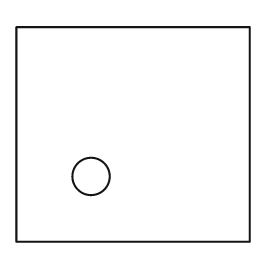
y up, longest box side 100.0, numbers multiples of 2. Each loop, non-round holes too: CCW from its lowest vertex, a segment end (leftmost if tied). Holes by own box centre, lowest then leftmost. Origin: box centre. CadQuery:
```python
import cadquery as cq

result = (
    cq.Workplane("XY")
    .moveTo(-50.0, -46.0)
    .lineTo(50.0, -46.0)
    .lineTo(50.0, 46.0)
    .lineTo(-50.0, 46.0)
    .close()
    .moveTo(-18.0, -18.0)
    .circle(8.0)
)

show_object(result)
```